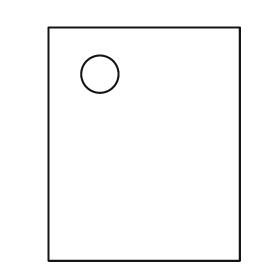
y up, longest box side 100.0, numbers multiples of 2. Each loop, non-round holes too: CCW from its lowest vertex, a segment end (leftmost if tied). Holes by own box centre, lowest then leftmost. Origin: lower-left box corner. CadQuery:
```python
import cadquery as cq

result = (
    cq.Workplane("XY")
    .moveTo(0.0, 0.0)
    .lineTo(82.0, 0.0)
    .lineTo(82.0, 100.0)
    .lineTo(0.0, 100.0)
    .close()
    .moveTo(22.0, 80.0)
    .circle(8.0)
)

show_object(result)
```